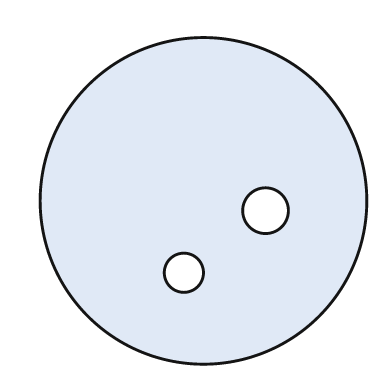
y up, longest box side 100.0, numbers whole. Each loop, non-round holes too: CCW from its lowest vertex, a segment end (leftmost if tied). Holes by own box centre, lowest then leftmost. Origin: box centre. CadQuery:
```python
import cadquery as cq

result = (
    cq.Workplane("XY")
    .moveTo(0.0, 0.0)
    .circle(50.0)
    .moveTo(-6.0, -22.0)
    .circle(6.0)
    .moveTo(19.0, -3.0)
    .circle(7.0)
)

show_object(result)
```